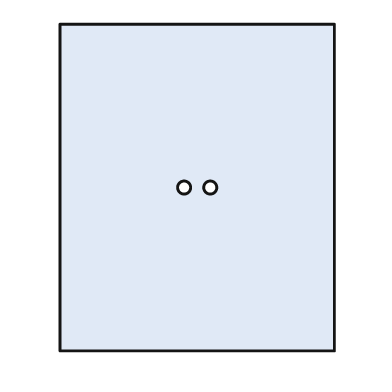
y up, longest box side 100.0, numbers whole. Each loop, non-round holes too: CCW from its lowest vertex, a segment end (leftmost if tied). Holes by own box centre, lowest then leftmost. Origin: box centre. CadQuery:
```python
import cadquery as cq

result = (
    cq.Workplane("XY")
    .moveTo(-42.0, -50.0)
    .lineTo(42.0, -50.0)
    .lineTo(42.0, 50.0)
    .lineTo(-42.0, 50.0)
    .close()
    .moveTo(-4.0, 0.0)
    .circle(2.0)
    .moveTo(4.0, 0.0)
    .circle(2.0)
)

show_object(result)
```